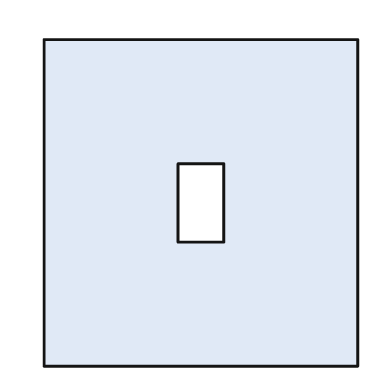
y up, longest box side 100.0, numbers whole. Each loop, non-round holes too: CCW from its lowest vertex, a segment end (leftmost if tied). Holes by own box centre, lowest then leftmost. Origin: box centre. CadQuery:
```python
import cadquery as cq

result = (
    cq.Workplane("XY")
    .moveTo(-48.0, -50.0)
    .lineTo(48.0, -50.0)
    .lineTo(48.0, 50.0)
    .lineTo(-48.0, 50.0)
    .close()
    .moveTo(-7.0, -12.0)
    .lineTo(7.0, -12.0)
    .lineTo(7.0, 12.0)
    .lineTo(-7.0, 12.0)
    .close()
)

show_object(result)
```